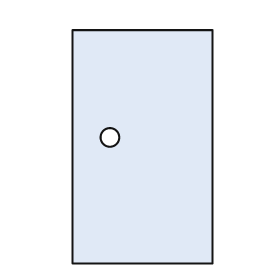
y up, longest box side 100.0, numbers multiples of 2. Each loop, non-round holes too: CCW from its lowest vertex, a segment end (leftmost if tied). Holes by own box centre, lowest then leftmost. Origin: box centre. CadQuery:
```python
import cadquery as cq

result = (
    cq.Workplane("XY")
    .moveTo(-30.0, -50.0)
    .lineTo(30.0, -50.0)
    .lineTo(30.0, 50.0)
    .lineTo(-30.0, 50.0)
    .close()
    .moveTo(-14.0, 4.0)
    .circle(4.0)
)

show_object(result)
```